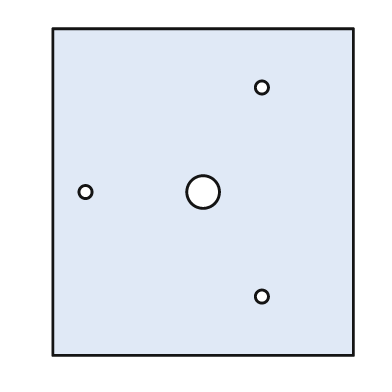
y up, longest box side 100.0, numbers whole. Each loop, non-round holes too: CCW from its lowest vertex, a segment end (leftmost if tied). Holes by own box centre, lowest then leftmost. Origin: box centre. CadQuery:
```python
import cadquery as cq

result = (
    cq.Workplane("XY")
    .moveTo(-46.0, -50.0)
    .lineTo(46.0, -50.0)
    .lineTo(46.0, 50.0)
    .lineTo(-46.0, 50.0)
    .close()
    .moveTo(18.0, -32.0)
    .circle(2.0)
    .moveTo(-36.0, 0.0)
    .circle(2.0)
    .moveTo(0.0, 0.0)
    .circle(5.0)
    .moveTo(18.0, 32.0)
    .circle(2.0)
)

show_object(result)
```